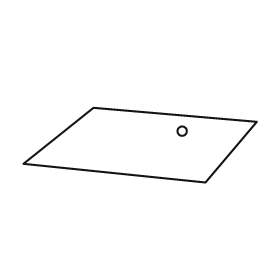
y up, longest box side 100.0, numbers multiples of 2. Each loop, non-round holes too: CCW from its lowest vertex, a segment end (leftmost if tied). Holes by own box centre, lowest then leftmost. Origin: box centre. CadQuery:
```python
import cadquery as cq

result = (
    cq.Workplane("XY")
    .moveTo(28.0, -16.0)
    .lineTo(50.0, 10.0)
    .lineTo(-20.0, 16.0)
    .lineTo(-50.0, -8.0)
    .close()
    .moveTo(18.0, 6.0)
    .circle(2.0)
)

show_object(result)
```